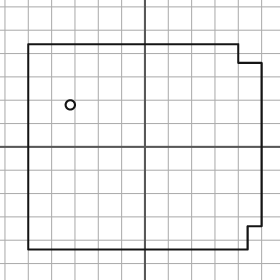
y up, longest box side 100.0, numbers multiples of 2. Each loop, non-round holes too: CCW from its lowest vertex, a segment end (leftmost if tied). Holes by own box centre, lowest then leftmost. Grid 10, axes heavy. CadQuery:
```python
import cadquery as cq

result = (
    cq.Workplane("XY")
    .moveTo(-50.0, -44.0)
    .lineTo(44.0, -44.0)
    .lineTo(44.0, -34.0)
    .lineTo(50.0, -34.0)
    .lineTo(50.0, 36.0)
    .lineTo(40.0, 36.0)
    .lineTo(40.0, 44.0)
    .lineTo(-50.0, 44.0)
    .close()
    .moveTo(-32.0, 18.0)
    .circle(2.0)
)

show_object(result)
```